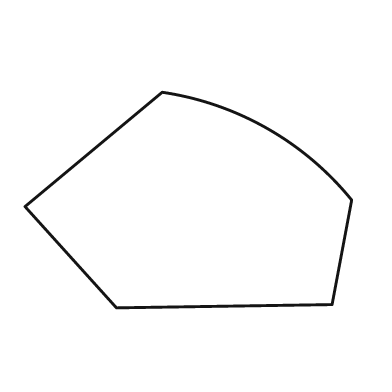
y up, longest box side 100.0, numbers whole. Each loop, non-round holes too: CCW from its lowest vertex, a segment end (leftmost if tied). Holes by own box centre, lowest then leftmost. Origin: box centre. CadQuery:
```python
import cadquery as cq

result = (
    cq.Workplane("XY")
    .moveTo(-22.0, -33.0)
    .lineTo(44.0, -32.0)
    .lineTo(50.0, 0.0)
    .threePointArc((24.0, 22.0), (-8.0, 33.0))
    .lineTo(-50.0, -2.0)
    .close()
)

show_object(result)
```